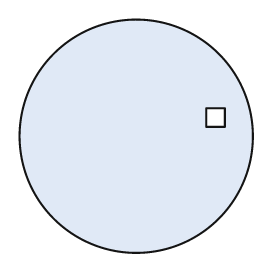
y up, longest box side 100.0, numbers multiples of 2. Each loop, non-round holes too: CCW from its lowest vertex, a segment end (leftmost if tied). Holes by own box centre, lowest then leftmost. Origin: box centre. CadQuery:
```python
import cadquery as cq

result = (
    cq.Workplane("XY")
    .moveTo(0.0, 0.0)
    .circle(50.0)
    .moveTo(30.0, 4.0)
    .lineTo(38.0, 4.0)
    .lineTo(38.0, 12.0)
    .lineTo(30.0, 12.0)
    .close()
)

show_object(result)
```